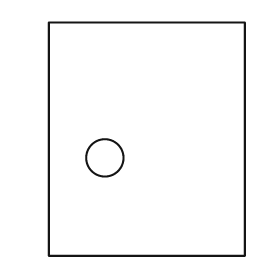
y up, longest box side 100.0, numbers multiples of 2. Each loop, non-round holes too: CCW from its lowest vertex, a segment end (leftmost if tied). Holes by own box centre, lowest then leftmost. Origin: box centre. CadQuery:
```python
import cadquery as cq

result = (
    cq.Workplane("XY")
    .moveTo(-42.0, -50.0)
    .lineTo(42.0, -50.0)
    .lineTo(42.0, 50.0)
    .lineTo(-42.0, 50.0)
    .close()
    .moveTo(-18.0, -8.0)
    .circle(8.0)
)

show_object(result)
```